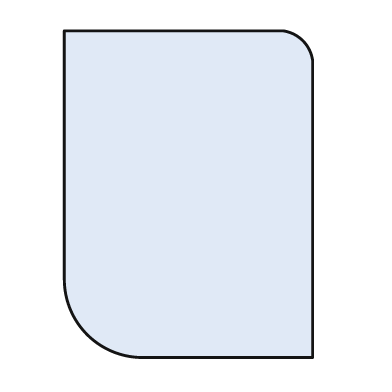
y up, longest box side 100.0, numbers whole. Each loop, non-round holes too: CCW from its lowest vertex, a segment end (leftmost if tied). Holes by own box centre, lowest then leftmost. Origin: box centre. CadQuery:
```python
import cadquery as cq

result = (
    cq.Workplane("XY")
    .moveTo(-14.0, -50.0)
    .lineTo(38.0, -50.0)
    .lineTo(38.0, 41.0)
    .threePointArc((35.0, 47.0), (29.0, 50.0))
    .lineTo(-38.0, 50.0)
    .lineTo(-38.0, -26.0)
    .threePointArc((-31.0, -43.0), (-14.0, -50.0))
    .close()
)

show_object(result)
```